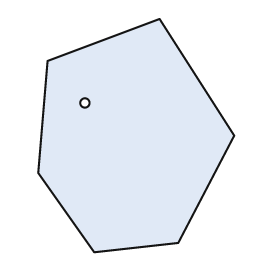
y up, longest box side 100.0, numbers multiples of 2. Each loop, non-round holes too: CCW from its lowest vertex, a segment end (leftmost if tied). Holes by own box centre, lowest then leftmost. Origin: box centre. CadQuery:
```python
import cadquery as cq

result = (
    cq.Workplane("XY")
    .moveTo(-18.0, -50.0)
    .lineTo(18.0, -46.0)
    .lineTo(42.0, 0.0)
    .lineTo(10.0, 50.0)
    .lineTo(-38.0, 32.0)
    .lineTo(-42.0, -16.0)
    .close()
    .moveTo(-22.0, 14.0)
    .circle(2.0)
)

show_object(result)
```